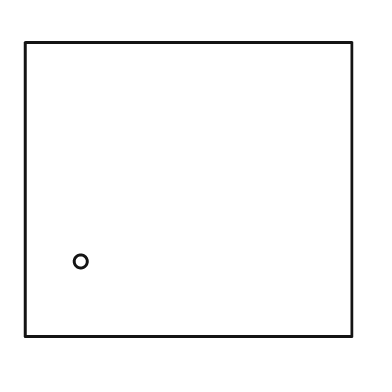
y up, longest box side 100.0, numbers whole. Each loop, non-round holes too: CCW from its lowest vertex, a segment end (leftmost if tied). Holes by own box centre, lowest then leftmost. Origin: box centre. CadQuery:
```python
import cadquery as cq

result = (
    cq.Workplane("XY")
    .moveTo(-50.0, -45.0)
    .lineTo(50.0, -45.0)
    .lineTo(50.0, 45.0)
    .lineTo(-50.0, 45.0)
    .close()
    .moveTo(-33.0, -22.0)
    .circle(2.0)
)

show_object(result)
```